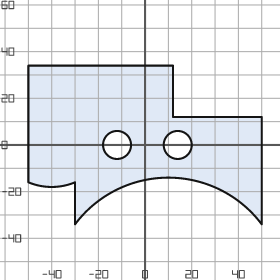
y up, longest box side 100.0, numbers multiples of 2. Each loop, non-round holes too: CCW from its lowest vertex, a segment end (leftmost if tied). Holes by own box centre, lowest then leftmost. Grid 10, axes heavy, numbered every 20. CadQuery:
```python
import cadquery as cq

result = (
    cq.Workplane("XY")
    .moveTo(-30.0, -34.0)
    .threePointArc((10.0, -14.0), (50.0, -34.0))
    .lineTo(50.0, 12.0)
    .lineTo(12.0, 12.0)
    .lineTo(12.0, 34.0)
    .lineTo(-50.0, 34.0)
    .lineTo(-50.0, -16.0)
    .threePointArc((-40.0, -18.0), (-30.0, -16.0))
    .close()
    .moveTo(-12.0, 0.0)
    .circle(6.0)
    .moveTo(14.0, 0.0)
    .circle(6.0)
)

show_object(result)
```